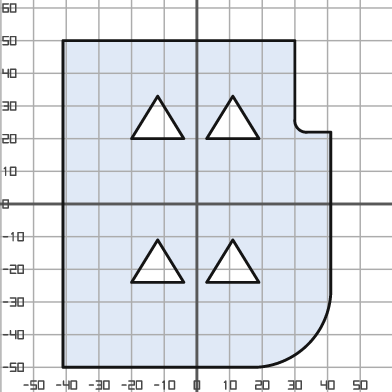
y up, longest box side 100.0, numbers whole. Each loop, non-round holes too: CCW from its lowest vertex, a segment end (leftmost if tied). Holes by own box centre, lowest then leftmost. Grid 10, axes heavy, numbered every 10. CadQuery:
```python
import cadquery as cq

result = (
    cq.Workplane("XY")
    .moveTo(-41.0, -50.0)
    .lineTo(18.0, -50.0)
    .threePointArc((34.0, -43.0), (41.0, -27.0))
    .lineTo(41.0, 22.0)
    .lineTo(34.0, 22.0)
    .threePointArc((31.0, 23.0), (30.0, 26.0))
    .lineTo(30.0, 50.0)
    .lineTo(-41.0, 50.0)
    .close()
    .moveTo(-20.0, -24.0)
    .lineTo(-4.0, -24.0)
    .lineTo(-12.0, -11.0)
    .close()
    .moveTo(3.0, -24.0)
    .lineTo(19.0, -24.0)
    .lineTo(11.0, -11.0)
    .close()
    .moveTo(-20.0, 20.0)
    .lineTo(-4.0, 20.0)
    .lineTo(-12.0, 33.0)
    .close()
    .moveTo(3.0, 20.0)
    .lineTo(19.0, 20.0)
    .lineTo(11.0, 33.0)
    .close()
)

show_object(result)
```